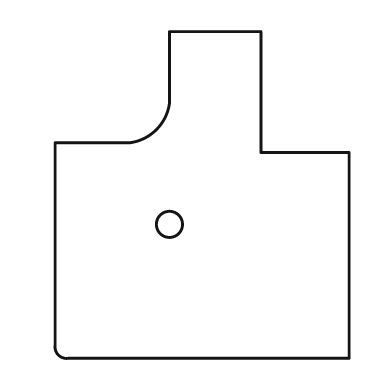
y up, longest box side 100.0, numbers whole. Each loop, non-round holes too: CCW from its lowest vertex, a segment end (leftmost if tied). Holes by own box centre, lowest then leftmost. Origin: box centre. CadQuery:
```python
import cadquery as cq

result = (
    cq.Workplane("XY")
    .moveTo(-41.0, -50.0)
    .lineTo(45.0, -50.0)
    .lineTo(45.0, 13.0)
    .lineTo(18.0, 13.0)
    .lineTo(18.0, 50.0)
    .lineTo(-10.0, 50.0)
    .lineTo(-10.0, 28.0)
    .threePointArc((-14.0, 20.0), (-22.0, 16.0))
    .lineTo(-45.0, 16.0)
    .lineTo(-45.0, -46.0)
    .threePointArc((-44.0, -49.0), (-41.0, -50.0))
    .close()
    .moveTo(-10.0, -9.0)
    .circle(4.0)
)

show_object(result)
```